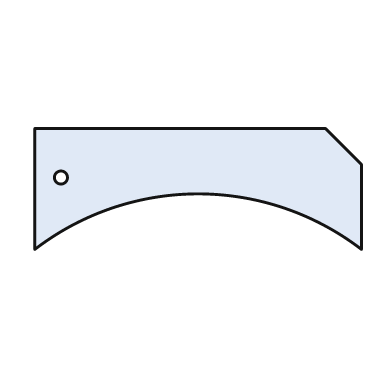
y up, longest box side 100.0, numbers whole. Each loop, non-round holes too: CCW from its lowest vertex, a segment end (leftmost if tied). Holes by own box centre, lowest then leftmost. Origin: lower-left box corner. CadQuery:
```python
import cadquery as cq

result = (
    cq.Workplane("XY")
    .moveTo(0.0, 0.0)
    .threePointArc((50.0, 17.0), (100.0, 0.0))
    .lineTo(100.0, 26.0)
    .lineTo(89.0, 37.0)
    .lineTo(0.0, 37.0)
    .close()
    .moveTo(8.0, 22.0)
    .circle(2.0)
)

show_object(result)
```